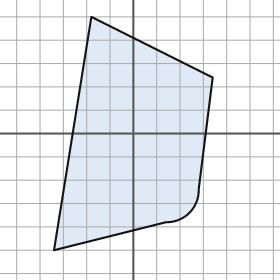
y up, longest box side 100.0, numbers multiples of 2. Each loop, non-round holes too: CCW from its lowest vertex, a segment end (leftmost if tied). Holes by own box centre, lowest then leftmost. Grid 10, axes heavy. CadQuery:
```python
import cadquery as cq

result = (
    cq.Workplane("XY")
    .moveTo(-34.0, -50.0)
    .lineTo(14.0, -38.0)
    .threePointArc((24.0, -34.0), (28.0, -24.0))
    .lineTo(34.0, 24.0)
    .lineTo(-18.0, 50.0)
    .close()
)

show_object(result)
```